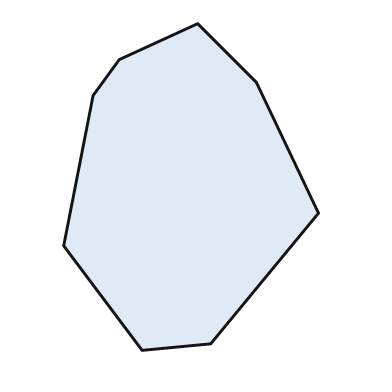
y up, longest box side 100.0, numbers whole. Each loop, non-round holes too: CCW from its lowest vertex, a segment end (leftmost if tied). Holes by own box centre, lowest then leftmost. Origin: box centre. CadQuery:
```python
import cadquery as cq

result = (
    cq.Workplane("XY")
    .moveTo(-15.0, -50.0)
    .lineTo(6.0, -48.0)
    .lineTo(39.0, -8.0)
    .lineTo(20.0, 32.0)
    .lineTo(2.0, 50.0)
    .lineTo(-22.0, 39.0)
    .lineTo(-30.0, 28.0)
    .lineTo(-39.0, -18.0)
    .close()
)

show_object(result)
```